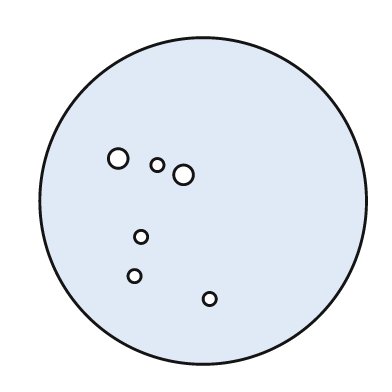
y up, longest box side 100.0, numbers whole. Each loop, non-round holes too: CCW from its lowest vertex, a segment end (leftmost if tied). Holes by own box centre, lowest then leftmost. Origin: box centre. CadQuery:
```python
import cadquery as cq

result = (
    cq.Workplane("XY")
    .moveTo(0.0, 0.0)
    .circle(50.0)
    .moveTo(2.0, -30.0)
    .circle(2.0)
    .moveTo(-21.0, -23.0)
    .circle(2.0)
    .moveTo(-19.0, -11.0)
    .circle(2.0)
    .moveTo(-6.0, 8.0)
    .circle(3.0)
    .moveTo(-14.0, 11.0)
    .circle(2.0)
    .moveTo(-26.0, 13.0)
    .circle(3.0)
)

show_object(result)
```